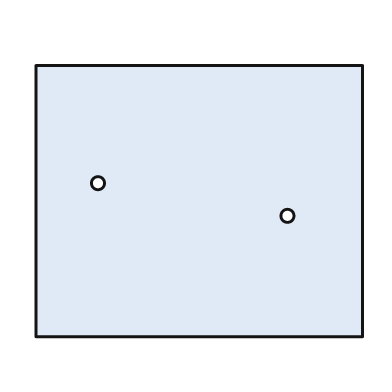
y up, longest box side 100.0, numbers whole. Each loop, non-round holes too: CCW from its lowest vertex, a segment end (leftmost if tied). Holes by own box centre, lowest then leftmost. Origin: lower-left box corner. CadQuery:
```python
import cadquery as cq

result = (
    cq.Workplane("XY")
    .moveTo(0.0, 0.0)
    .lineTo(100.0, 0.0)
    .lineTo(100.0, 83.0)
    .lineTo(0.0, 83.0)
    .close()
    .moveTo(77.0, 37.0)
    .circle(2.0)
    .moveTo(19.0, 47.0)
    .circle(2.0)
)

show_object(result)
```